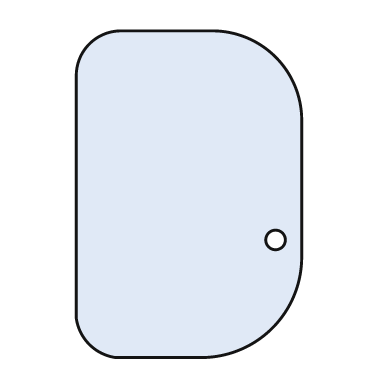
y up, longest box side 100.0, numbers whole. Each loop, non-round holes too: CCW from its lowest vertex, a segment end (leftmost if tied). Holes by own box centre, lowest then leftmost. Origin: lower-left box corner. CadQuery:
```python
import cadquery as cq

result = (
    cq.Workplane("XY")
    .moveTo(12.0, 0.0)
    .lineTo(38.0, 0.0)
    .threePointArc((60.0, 9.0), (69.0, 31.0))
    .lineTo(69.0, 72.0)
    .threePointArc((61.0, 92.0), (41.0, 100.0))
    .lineTo(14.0, 100.0)
    .threePointArc((4.0, 96.0), (0.0, 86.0))
    .lineTo(0.0, 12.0)
    .threePointArc((4.0, 4.0), (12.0, 0.0))
    .close()
    .moveTo(61.0, 36.0)
    .circle(3.0)
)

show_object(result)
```